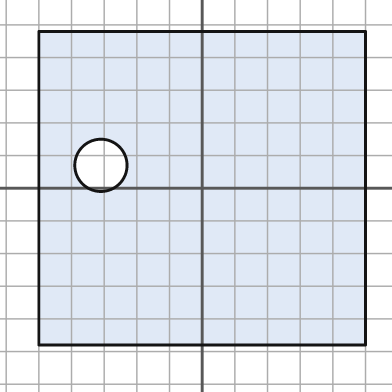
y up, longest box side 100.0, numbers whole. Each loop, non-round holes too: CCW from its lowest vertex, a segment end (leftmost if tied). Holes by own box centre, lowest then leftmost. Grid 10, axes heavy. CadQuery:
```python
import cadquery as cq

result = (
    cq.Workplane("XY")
    .moveTo(-50.0, -48.0)
    .lineTo(50.0, -48.0)
    .lineTo(50.0, 48.0)
    .lineTo(-50.0, 48.0)
    .close()
    .moveTo(-31.0, 7.0)
    .circle(8.0)
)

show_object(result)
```